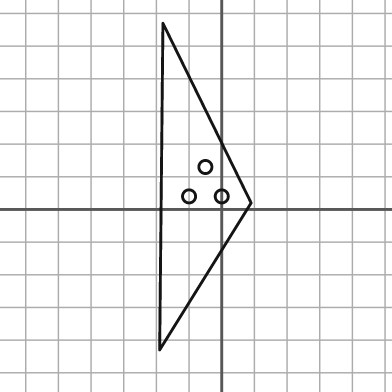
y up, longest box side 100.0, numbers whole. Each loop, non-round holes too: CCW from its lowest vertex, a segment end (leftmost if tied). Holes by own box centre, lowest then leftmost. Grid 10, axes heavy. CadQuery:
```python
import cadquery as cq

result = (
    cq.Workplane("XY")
    .moveTo(-19.0, -43.0)
    .lineTo(9.0, 2.0)
    .lineTo(-18.0, 57.0)
    .close()
    .moveTo(-10.0, 4.0)
    .circle(2.0)
    .moveTo(0.0, 4.0)
    .circle(2.0)
    .moveTo(-5.0, 13.0)
    .circle(2.0)
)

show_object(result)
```